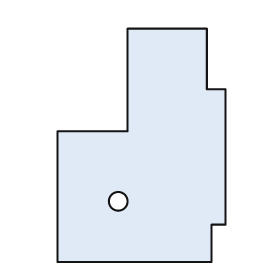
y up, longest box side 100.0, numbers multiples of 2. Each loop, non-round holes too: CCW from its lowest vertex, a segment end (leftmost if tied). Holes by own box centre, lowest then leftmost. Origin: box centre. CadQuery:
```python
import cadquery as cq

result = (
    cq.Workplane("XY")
    .moveTo(-36.0, -50.0)
    .lineTo(30.0, -50.0)
    .lineTo(30.0, -34.0)
    .lineTo(36.0, -34.0)
    .lineTo(36.0, 24.0)
    .lineTo(28.0, 24.0)
    .lineTo(28.0, 50.0)
    .lineTo(-6.0, 50.0)
    .lineTo(-6.0, 6.0)
    .lineTo(-36.0, 6.0)
    .close()
    .moveTo(-10.0, -24.0)
    .circle(4.0)
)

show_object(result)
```